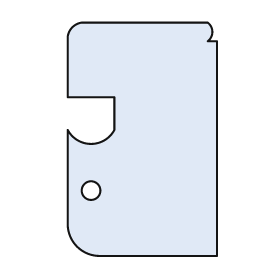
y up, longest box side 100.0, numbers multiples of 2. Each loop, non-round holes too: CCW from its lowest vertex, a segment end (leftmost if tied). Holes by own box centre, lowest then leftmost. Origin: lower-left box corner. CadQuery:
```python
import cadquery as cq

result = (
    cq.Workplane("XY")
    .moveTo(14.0, 0.0)
    .lineTo(64.0, 0.0)
    .lineTo(64.0, 92.0)
    .lineTo(60.0, 92.0)
    .threePointArc((62.0, 96.0), (60.0, 100.0))
    .lineTo(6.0, 100.0)
    .threePointArc((2.0, 98.0), (0.0, 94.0))
    .lineTo(0.0, 68.0)
    .lineTo(20.0, 68.0)
    .lineTo(20.0, 54.0)
    .threePointArc((10.0, 48.0), (0.0, 54.0))
    .lineTo(0.0, 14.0)
    .threePointArc((4.0, 4.0), (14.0, 0.0))
    .close()
    .moveTo(10.0, 28.0)
    .circle(4.0)
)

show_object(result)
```